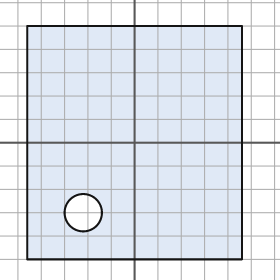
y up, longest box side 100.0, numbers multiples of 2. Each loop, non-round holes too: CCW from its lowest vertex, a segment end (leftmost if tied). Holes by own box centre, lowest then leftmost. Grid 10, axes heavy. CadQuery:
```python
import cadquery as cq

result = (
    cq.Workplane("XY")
    .moveTo(-46.0, -50.0)
    .lineTo(46.0, -50.0)
    .lineTo(46.0, 50.0)
    .lineTo(-46.0, 50.0)
    .close()
    .moveTo(-22.0, -30.0)
    .circle(8.0)
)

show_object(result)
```